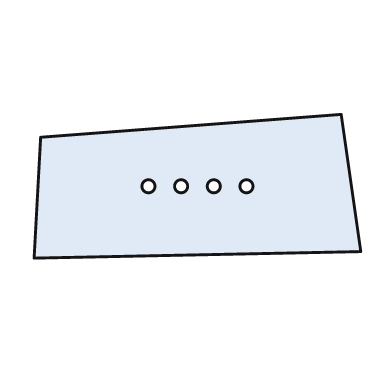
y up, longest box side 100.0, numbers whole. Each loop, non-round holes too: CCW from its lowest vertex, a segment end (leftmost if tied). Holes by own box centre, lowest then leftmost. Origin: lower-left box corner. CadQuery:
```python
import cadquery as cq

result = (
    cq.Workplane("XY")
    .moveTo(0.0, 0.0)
    .lineTo(100.0, 2.0)
    .lineTo(94.0, 44.0)
    .lineTo(2.0, 37.0)
    .close()
    .moveTo(35.0, 22.0)
    .circle(2.0)
    .moveTo(45.0, 22.0)
    .circle(2.0)
    .moveTo(55.0, 22.0)
    .circle(2.0)
    .moveTo(65.0, 22.0)
    .circle(2.0)
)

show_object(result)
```